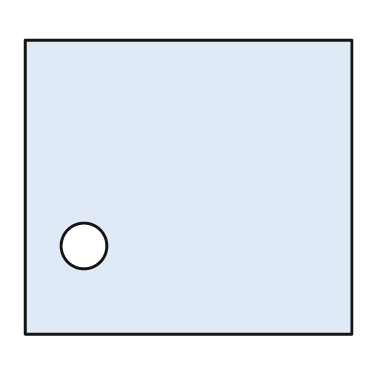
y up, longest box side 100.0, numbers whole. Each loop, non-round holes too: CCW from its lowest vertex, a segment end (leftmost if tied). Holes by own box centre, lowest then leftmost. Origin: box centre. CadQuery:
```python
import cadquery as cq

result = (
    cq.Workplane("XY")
    .moveTo(-50.0, -45.0)
    .lineTo(50.0, -45.0)
    .lineTo(50.0, 45.0)
    .lineTo(-50.0, 45.0)
    .close()
    .moveTo(-32.0, -18.0)
    .circle(7.0)
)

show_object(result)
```